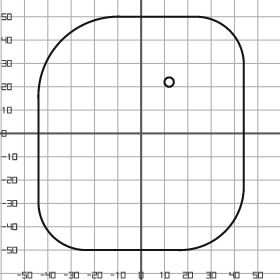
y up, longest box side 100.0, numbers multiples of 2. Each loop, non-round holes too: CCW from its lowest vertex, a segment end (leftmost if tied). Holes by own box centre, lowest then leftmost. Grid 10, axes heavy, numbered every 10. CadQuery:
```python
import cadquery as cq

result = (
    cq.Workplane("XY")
    .moveTo(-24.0, -50.0)
    .lineTo(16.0, -50.0)
    .threePointArc((36.0, -42.0), (44.0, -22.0))
    .lineTo(44.0, 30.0)
    .threePointArc((38.0, 44.0), (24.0, 50.0))
    .lineTo(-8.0, 50.0)
    .threePointArc((-34.0, 40.0), (-44.0, 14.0))
    .lineTo(-44.0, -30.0)
    .threePointArc((-38.0, -44.0), (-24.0, -50.0))
    .close()
    .moveTo(12.0, 22.0)
    .circle(2.0)
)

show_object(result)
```